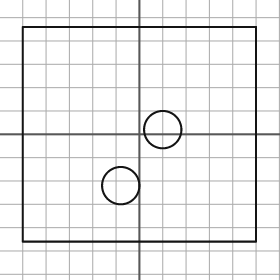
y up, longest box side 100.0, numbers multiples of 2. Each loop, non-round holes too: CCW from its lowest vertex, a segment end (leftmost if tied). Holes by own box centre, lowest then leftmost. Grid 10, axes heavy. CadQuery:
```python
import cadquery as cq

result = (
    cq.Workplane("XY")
    .moveTo(-50.0, -46.0)
    .lineTo(50.0, -46.0)
    .lineTo(50.0, 46.0)
    .lineTo(-50.0, 46.0)
    .close()
    .moveTo(-8.0, -22.0)
    .circle(8.0)
    .moveTo(10.0, 2.0)
    .circle(8.0)
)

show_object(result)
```